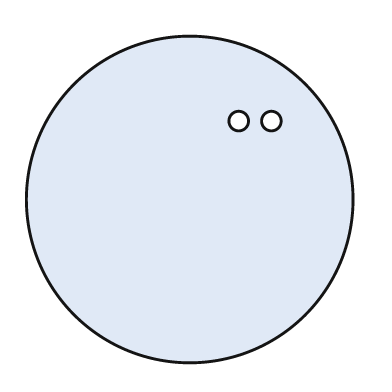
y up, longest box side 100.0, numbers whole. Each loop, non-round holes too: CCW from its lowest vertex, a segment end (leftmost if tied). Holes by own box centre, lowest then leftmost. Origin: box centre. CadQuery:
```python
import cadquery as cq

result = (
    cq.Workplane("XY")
    .moveTo(0.0, 0.0)
    .circle(50.0)
    .moveTo(15.0, 24.0)
    .circle(3.0)
    .moveTo(25.0, 24.0)
    .circle(3.0)
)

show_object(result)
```